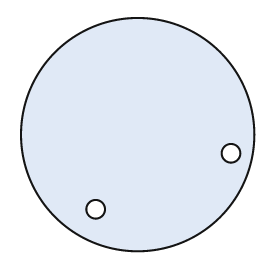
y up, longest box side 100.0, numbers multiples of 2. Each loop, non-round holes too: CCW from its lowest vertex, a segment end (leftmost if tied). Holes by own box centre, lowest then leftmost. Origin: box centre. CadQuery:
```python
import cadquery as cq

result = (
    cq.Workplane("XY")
    .moveTo(0.0, 0.0)
    .circle(50.0)
    .moveTo(-18.0, -32.0)
    .circle(4.0)
    .moveTo(40.0, -8.0)
    .circle(4.0)
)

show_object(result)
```